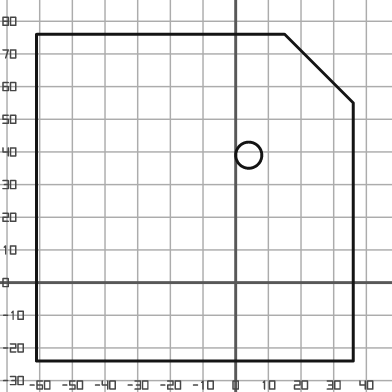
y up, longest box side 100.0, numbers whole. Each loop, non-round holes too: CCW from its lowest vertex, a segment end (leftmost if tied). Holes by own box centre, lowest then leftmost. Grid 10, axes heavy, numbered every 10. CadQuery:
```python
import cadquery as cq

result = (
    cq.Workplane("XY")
    .moveTo(-61.0, -24.0)
    .lineTo(36.0, -24.0)
    .lineTo(36.0, 55.0)
    .lineTo(15.0, 76.0)
    .lineTo(-61.0, 76.0)
    .close()
    .moveTo(4.0, 39.0)
    .circle(4.0)
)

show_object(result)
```